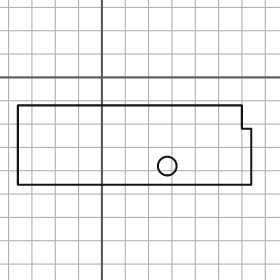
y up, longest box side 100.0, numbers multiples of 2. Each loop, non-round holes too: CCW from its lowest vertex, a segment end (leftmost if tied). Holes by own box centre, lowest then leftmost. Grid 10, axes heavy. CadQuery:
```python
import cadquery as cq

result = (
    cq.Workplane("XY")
    .moveTo(-36.0, -46.0)
    .lineTo(64.0, -46.0)
    .lineTo(64.0, -22.0)
    .lineTo(60.0, -22.0)
    .lineTo(60.0, -12.0)
    .lineTo(-36.0, -12.0)
    .close()
    .moveTo(28.0, -38.0)
    .circle(4.0)
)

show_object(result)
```